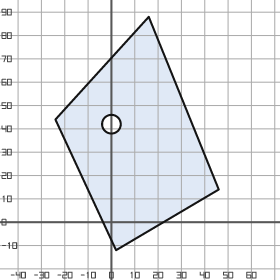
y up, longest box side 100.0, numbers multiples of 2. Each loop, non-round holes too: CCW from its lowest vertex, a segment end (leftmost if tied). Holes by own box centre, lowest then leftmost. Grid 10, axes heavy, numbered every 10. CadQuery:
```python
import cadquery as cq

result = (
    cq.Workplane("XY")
    .moveTo(2.0, -12.0)
    .lineTo(46.0, 14.0)
    .lineTo(16.0, 88.0)
    .lineTo(-24.0, 44.0)
    .close()
    .moveTo(0.0, 42.0)
    .circle(4.0)
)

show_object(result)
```